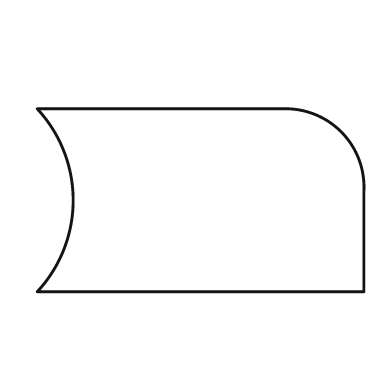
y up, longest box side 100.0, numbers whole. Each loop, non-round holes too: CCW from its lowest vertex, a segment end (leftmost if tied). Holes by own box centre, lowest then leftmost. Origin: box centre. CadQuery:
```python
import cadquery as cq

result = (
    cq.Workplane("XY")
    .moveTo(-50.0, -28.0)
    .lineTo(50.0, -28.0)
    .lineTo(50.0, 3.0)
    .threePointArc((43.0, 21.0), (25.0, 28.0))
    .lineTo(-50.0, 28.0)
    .threePointArc((-39.0, 0.0), (-50.0, -28.0))
    .close()
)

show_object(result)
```